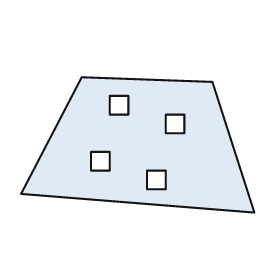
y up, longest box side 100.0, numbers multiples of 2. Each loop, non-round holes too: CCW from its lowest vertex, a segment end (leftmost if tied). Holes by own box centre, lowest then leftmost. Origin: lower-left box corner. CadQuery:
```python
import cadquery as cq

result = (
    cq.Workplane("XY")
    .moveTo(100.0, 0.0)
    .lineTo(82.0, 56.0)
    .lineTo(26.0, 58.0)
    .lineTo(0.0, 8.0)
    .close()
    .moveTo(54.0, 10.0)
    .lineTo(62.0, 10.0)
    .lineTo(62.0, 18.0)
    .lineTo(54.0, 18.0)
    .close()
    .moveTo(30.0, 18.0)
    .lineTo(38.0, 18.0)
    .lineTo(38.0, 26.0)
    .lineTo(30.0, 26.0)
    .close()
    .moveTo(62.0, 34.0)
    .lineTo(70.0, 34.0)
    .lineTo(70.0, 42.0)
    .lineTo(62.0, 42.0)
    .close()
    .moveTo(38.0, 42.0)
    .lineTo(46.0, 42.0)
    .lineTo(46.0, 50.0)
    .lineTo(38.0, 50.0)
    .close()
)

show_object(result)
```